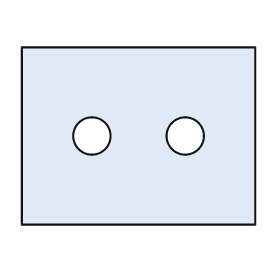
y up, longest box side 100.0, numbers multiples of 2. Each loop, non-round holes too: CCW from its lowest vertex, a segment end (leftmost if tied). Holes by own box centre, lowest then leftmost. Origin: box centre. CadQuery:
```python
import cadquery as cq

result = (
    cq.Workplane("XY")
    .moveTo(-50.0, -38.0)
    .lineTo(50.0, -38.0)
    .lineTo(50.0, 38.0)
    .lineTo(-50.0, 38.0)
    .close()
    .moveTo(-20.0, 0.0)
    .circle(8.0)
    .moveTo(20.0, 0.0)
    .circle(8.0)
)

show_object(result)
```